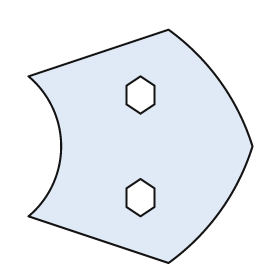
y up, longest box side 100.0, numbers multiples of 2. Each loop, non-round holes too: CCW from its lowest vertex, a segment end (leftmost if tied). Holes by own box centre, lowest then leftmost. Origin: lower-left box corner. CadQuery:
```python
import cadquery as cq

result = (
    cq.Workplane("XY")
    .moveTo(60.0, 0.0)
    .threePointArc((82.0, 22.0), (96.0, 50.0))
    .threePointArc((82.0, 78.0), (60.0, 100.0))
    .lineTo(0.0, 80.0)
    .threePointArc((14.0, 50.0), (0.0, 20.0))
    .close()
    .moveTo(48.0, 20.0)
    .lineTo(54.0, 24.0)
    .lineTo(54.0, 32.0)
    .lineTo(48.0, 36.0)
    .lineTo(42.0, 32.0)
    .lineTo(42.0, 24.0)
    .close()
    .moveTo(48.0, 64.0)
    .lineTo(54.0, 68.0)
    .lineTo(54.0, 76.0)
    .lineTo(48.0, 80.0)
    .lineTo(42.0, 76.0)
    .lineTo(42.0, 68.0)
    .close()
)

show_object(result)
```